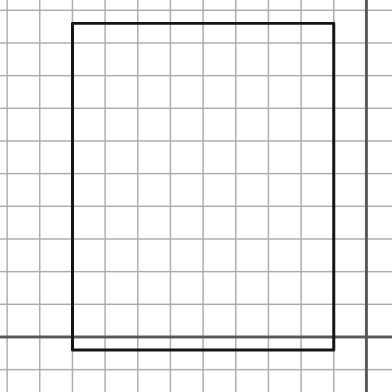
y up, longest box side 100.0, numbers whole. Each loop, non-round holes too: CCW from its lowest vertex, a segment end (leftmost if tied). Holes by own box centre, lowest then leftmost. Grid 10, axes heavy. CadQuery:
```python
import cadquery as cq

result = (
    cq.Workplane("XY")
    .moveTo(-90.0, -4.0)
    .lineTo(-10.0, -4.0)
    .lineTo(-10.0, 96.0)
    .lineTo(-90.0, 96.0)
    .close()
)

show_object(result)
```